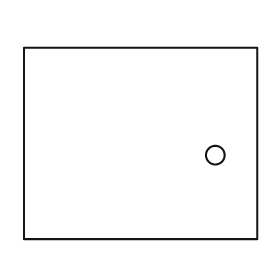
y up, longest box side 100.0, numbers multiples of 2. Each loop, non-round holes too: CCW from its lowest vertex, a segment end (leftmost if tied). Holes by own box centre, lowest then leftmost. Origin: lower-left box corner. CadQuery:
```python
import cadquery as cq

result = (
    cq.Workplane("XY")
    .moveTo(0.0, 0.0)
    .lineTo(100.0, 0.0)
    .lineTo(100.0, 82.0)
    .lineTo(0.0, 82.0)
    .close()
    .moveTo(82.0, 36.0)
    .circle(4.0)
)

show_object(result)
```